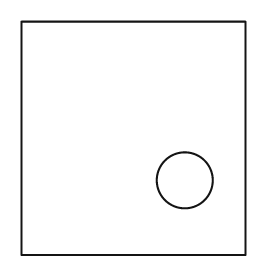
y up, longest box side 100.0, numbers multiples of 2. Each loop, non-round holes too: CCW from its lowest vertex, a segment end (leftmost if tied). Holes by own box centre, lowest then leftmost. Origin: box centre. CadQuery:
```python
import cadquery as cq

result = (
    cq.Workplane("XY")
    .moveTo(-48.0, -50.0)
    .lineTo(48.0, -50.0)
    .lineTo(48.0, 50.0)
    .lineTo(-48.0, 50.0)
    .close()
    .moveTo(22.0, -18.0)
    .circle(12.0)
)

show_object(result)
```